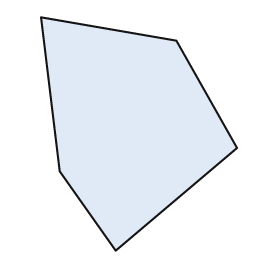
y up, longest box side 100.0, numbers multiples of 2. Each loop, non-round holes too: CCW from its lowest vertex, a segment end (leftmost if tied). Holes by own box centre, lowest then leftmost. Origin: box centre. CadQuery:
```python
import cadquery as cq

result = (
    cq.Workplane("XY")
    .moveTo(-10.0, -50.0)
    .lineTo(42.0, -6.0)
    .lineTo(16.0, 40.0)
    .lineTo(-42.0, 50.0)
    .lineTo(-34.0, -16.0)
    .close()
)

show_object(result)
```